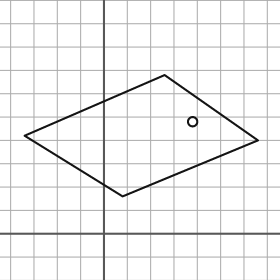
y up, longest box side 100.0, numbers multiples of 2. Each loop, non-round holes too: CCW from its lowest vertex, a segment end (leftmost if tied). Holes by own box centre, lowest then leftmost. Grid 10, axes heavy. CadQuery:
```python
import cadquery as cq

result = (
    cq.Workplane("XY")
    .moveTo(8.0, 16.0)
    .lineTo(66.0, 40.0)
    .lineTo(26.0, 68.0)
    .lineTo(-34.0, 42.0)
    .close()
    .moveTo(38.0, 48.0)
    .circle(2.0)
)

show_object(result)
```